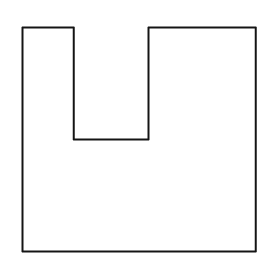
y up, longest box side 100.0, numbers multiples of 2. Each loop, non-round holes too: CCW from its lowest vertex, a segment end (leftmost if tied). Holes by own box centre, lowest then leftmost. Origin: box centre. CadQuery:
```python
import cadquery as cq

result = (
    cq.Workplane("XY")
    .moveTo(-50.0, -48.0)
    .lineTo(50.0, -48.0)
    .lineTo(50.0, 48.0)
    .lineTo(4.0, 48.0)
    .lineTo(4.0, 0.0)
    .lineTo(-28.0, 0.0)
    .lineTo(-28.0, 48.0)
    .lineTo(-50.0, 48.0)
    .close()
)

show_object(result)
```